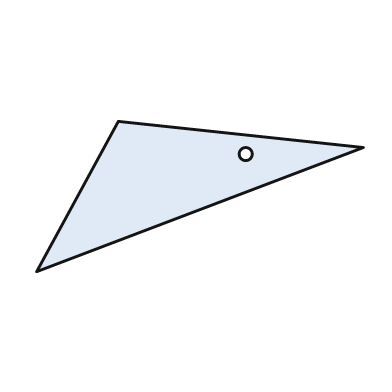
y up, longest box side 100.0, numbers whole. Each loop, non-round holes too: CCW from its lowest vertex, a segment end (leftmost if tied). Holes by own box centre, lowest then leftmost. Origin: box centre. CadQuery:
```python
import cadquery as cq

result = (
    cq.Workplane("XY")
    .moveTo(-50.0, -23.0)
    .lineTo(50.0, 15.0)
    .lineTo(-25.0, 23.0)
    .close()
    .moveTo(14.0, 13.0)
    .circle(2.0)
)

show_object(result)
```